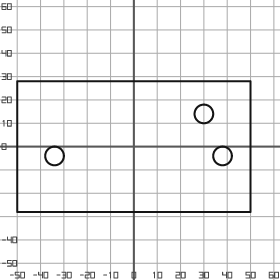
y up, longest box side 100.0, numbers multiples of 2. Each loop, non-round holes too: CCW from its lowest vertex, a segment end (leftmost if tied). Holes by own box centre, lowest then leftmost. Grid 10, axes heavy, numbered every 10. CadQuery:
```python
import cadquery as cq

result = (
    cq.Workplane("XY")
    .moveTo(-50.0, -28.0)
    .lineTo(50.0, -28.0)
    .lineTo(50.0, 28.0)
    .lineTo(-50.0, 28.0)
    .close()
    .moveTo(-34.0, -4.0)
    .circle(4.0)
    .moveTo(38.0, -4.0)
    .circle(4.0)
    .moveTo(30.0, 14.0)
    .circle(4.0)
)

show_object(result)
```